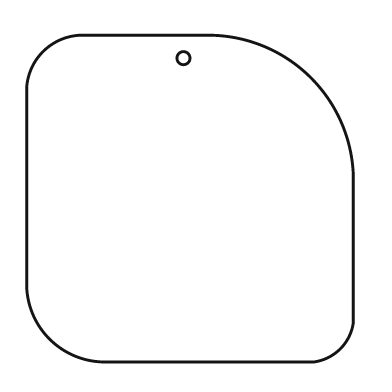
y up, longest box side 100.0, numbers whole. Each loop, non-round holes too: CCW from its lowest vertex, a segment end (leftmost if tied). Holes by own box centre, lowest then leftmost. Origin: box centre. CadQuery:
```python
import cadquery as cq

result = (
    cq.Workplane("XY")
    .moveTo(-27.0, -50.0)
    .lineTo(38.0, -50.0)
    .threePointArc((46.0, -46.0), (50.0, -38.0))
    .lineTo(50.0, 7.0)
    .threePointArc((37.0, 37.0), (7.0, 50.0))
    .lineTo(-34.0, 50.0)
    .threePointArc((-45.0, 45.0), (-50.0, 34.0))
    .lineTo(-50.0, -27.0)
    .threePointArc((-43.0, -43.0), (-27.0, -50.0))
    .close()
    .moveTo(-2.0, 43.0)
    .circle(2.0)
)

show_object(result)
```